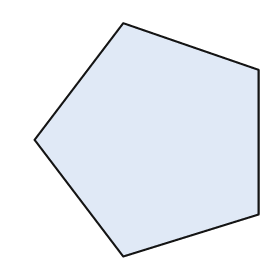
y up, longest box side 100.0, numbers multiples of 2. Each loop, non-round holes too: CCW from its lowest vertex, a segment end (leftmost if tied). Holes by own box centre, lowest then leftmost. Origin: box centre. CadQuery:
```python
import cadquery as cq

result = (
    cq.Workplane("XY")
    .moveTo(-10.0, -50.0)
    .lineTo(48.0, -32.0)
    .lineTo(48.0, 30.0)
    .lineTo(-10.0, 50.0)
    .lineTo(-48.0, 0.0)
    .close()
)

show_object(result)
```